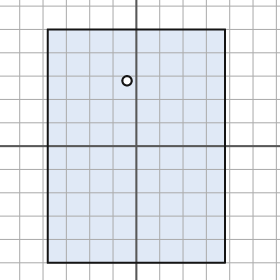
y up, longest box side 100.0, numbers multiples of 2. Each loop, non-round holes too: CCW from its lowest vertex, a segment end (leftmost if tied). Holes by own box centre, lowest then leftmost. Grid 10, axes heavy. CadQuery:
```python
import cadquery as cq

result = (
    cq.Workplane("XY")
    .moveTo(-38.0, -50.0)
    .lineTo(38.0, -50.0)
    .lineTo(38.0, 50.0)
    .lineTo(-38.0, 50.0)
    .close()
    .moveTo(-4.0, 28.0)
    .circle(2.0)
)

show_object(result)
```